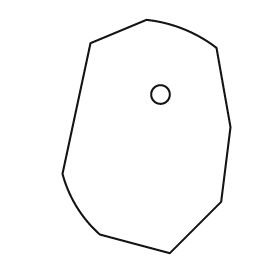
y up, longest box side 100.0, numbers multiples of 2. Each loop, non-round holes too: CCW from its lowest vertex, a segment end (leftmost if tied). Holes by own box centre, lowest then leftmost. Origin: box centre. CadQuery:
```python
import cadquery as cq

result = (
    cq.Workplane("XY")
    .moveTo(10.0, -50.0)
    .lineTo(32.0, -28.0)
    .lineTo(36.0, 4.0)
    .lineTo(30.0, 38.0)
    .threePointArc((16.0, 46.0), (0.0, 50.0))
    .lineTo(-24.0, 40.0)
    .lineTo(-36.0, -16.0)
    .threePointArc((-30.0, -30.0), (-20.0, -42.0))
    .close()
    .moveTo(6.0, 18.0)
    .circle(4.0)
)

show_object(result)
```